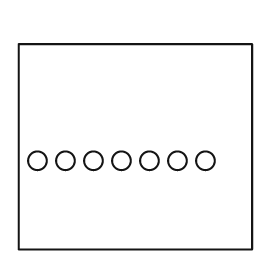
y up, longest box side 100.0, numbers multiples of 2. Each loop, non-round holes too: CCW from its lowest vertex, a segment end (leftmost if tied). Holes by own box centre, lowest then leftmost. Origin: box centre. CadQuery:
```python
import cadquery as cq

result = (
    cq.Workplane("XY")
    .moveTo(-50.0, -44.0)
    .lineTo(50.0, -44.0)
    .lineTo(50.0, 44.0)
    .lineTo(-50.0, 44.0)
    .close()
    .moveTo(-42.0, -6.0)
    .circle(4.0)
    .moveTo(-30.0, -6.0)
    .circle(4.0)
    .moveTo(-18.0, -6.0)
    .circle(4.0)
    .moveTo(-6.0, -6.0)
    .circle(4.0)
    .moveTo(6.0, -6.0)
    .circle(4.0)
    .moveTo(18.0, -6.0)
    .circle(4.0)
    .moveTo(30.0, -6.0)
    .circle(4.0)
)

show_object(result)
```